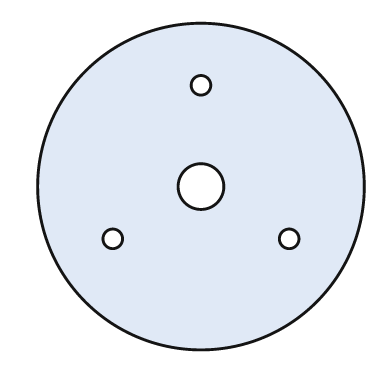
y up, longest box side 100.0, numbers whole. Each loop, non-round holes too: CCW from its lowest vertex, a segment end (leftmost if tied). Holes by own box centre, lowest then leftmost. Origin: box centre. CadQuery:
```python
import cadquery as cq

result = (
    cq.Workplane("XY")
    .moveTo(0.0, 0.0)
    .circle(50.0)
    .moveTo(-27.0, -16.0)
    .circle(3.0)
    .moveTo(27.0, -16.0)
    .circle(3.0)
    .moveTo(0.0, 0.0)
    .circle(7.0)
    .moveTo(0.0, 31.0)
    .circle(3.0)
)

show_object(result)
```